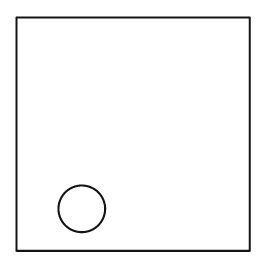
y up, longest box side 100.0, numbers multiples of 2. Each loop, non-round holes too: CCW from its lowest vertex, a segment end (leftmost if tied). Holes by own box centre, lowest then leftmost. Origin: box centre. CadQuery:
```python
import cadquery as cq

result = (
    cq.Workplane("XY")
    .moveTo(-50.0, -50.0)
    .lineTo(50.0, -50.0)
    .lineTo(50.0, 50.0)
    .lineTo(-50.0, 50.0)
    .close()
    .moveTo(-22.0, -32.0)
    .circle(10.0)
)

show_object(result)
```